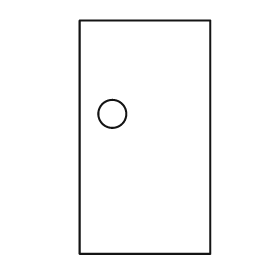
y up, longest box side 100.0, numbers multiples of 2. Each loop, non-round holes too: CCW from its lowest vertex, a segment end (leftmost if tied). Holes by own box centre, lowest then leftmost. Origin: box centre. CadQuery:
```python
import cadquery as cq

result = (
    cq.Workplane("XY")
    .moveTo(-28.0, -50.0)
    .lineTo(28.0, -50.0)
    .lineTo(28.0, 50.0)
    .lineTo(-28.0, 50.0)
    .close()
    .moveTo(-14.0, 10.0)
    .circle(6.0)
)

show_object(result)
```